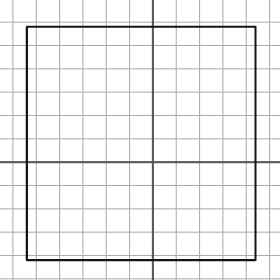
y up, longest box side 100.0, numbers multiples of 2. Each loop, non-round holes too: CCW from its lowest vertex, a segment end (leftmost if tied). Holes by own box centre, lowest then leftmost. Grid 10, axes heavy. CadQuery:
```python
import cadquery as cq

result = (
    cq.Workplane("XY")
    .moveTo(-54.0, -42.0)
    .lineTo(44.0, -42.0)
    .lineTo(44.0, 58.0)
    .lineTo(-54.0, 58.0)
    .close()
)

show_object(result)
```